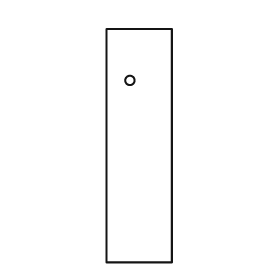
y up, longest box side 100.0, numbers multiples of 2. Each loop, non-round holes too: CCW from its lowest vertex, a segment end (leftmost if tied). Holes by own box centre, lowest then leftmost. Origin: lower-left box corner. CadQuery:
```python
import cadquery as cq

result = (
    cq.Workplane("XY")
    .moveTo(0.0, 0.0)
    .lineTo(28.0, 0.0)
    .lineTo(28.0, 100.0)
    .lineTo(0.0, 100.0)
    .close()
    .moveTo(10.0, 78.0)
    .circle(2.0)
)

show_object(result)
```